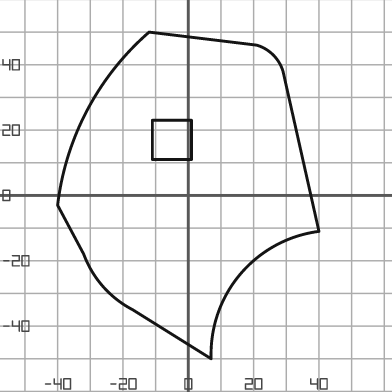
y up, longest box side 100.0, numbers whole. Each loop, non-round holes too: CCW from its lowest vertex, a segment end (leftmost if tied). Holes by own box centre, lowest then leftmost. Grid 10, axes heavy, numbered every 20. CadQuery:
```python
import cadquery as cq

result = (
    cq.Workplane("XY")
    .moveTo(7.0, -50.0)
    .threePointArc((16.0, -24.0), (40.0, -11.0))
    .lineTo(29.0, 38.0)
    .threePointArc((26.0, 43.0), (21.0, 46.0))
    .lineTo(-12.0, 50.0)
    .threePointArc((-31.0, 26.0), (-40.0, -3.0))
    .lineTo(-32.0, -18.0)
    .threePointArc((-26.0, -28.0), (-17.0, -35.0))
    .close()
    .moveTo(-11.0, 11.0)
    .lineTo(1.0, 11.0)
    .lineTo(1.0, 23.0)
    .lineTo(-11.0, 23.0)
    .close()
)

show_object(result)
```